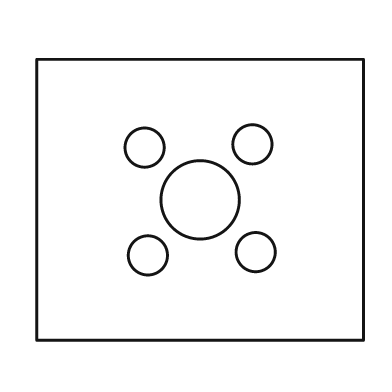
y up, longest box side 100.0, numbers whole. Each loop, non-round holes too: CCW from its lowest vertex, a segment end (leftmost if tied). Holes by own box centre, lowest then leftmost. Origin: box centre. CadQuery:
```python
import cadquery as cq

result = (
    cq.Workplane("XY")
    .moveTo(-50.0, -43.0)
    .lineTo(50.0, -43.0)
    .lineTo(50.0, 43.0)
    .lineTo(-50.0, 43.0)
    .close()
    .moveTo(-16.0, -17.0)
    .circle(6.0)
    .moveTo(17.0, -16.0)
    .circle(6.0)
    .moveTo(0.0, 0.0)
    .circle(12.0)
    .moveTo(-17.0, 16.0)
    .circle(6.0)
    .moveTo(16.0, 17.0)
    .circle(6.0)
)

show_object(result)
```